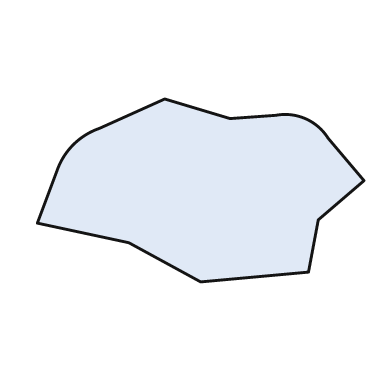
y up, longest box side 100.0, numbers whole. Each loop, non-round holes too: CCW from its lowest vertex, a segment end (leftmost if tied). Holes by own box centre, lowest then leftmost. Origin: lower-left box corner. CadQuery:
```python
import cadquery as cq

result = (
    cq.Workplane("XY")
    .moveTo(50.0, 0.0)
    .lineTo(83.0, 3.0)
    .lineTo(86.0, 19.0)
    .lineTo(100.0, 31.0)
    .lineTo(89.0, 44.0)
    .threePointArc((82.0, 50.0), (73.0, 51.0))
    .lineTo(59.0, 50.0)
    .lineTo(39.0, 56.0)
    .lineTo(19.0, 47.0)
    .threePointArc((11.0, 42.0), (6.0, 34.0))
    .lineTo(0.0, 18.0)
    .lineTo(28.0, 12.0)
    .close()
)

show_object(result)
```